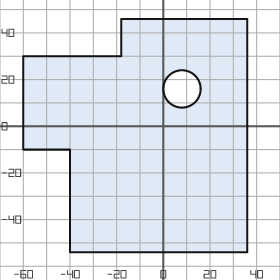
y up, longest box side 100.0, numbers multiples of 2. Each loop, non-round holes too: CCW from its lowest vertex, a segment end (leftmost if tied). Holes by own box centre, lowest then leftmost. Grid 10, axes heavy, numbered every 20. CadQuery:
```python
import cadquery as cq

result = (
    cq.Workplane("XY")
    .moveTo(-40.0, -54.0)
    .lineTo(36.0, -54.0)
    .lineTo(36.0, 46.0)
    .lineTo(-18.0, 46.0)
    .lineTo(-18.0, 30.0)
    .lineTo(-60.0, 30.0)
    .lineTo(-60.0, -10.0)
    .lineTo(-40.0, -10.0)
    .close()
    .moveTo(8.0, 16.0)
    .circle(8.0)
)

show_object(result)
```